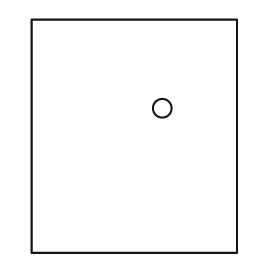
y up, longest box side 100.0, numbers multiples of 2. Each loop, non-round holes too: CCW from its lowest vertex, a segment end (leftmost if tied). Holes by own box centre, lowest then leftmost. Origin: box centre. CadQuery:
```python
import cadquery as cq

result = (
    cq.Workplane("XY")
    .moveTo(-44.0, -50.0)
    .lineTo(44.0, -50.0)
    .lineTo(44.0, 50.0)
    .lineTo(-44.0, 50.0)
    .close()
    .moveTo(12.0, 12.0)
    .circle(4.0)
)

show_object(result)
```